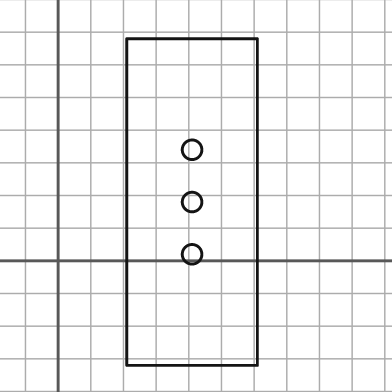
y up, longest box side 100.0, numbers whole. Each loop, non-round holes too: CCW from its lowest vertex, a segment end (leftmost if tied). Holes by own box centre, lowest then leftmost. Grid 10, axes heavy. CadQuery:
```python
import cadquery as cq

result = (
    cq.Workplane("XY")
    .moveTo(21.0, -32.0)
    .lineTo(61.0, -32.0)
    .lineTo(61.0, 68.0)
    .lineTo(21.0, 68.0)
    .close()
    .moveTo(41.0, 2.0)
    .circle(3.0)
    .moveTo(41.0, 18.0)
    .circle(3.0)
    .moveTo(41.0, 34.0)
    .circle(3.0)
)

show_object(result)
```